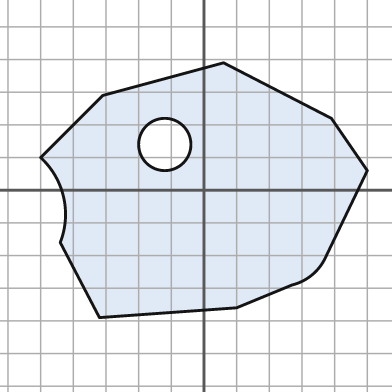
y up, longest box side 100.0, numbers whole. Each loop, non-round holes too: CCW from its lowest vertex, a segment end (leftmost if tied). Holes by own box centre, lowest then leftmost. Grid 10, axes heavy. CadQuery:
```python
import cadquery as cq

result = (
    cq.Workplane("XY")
    .moveTo(-32.0, -39.0)
    .lineTo(10.0, -36.0)
    .lineTo(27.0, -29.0)
    .threePointArc((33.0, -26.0), (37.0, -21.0))
    .lineTo(50.0, 6.0)
    .lineTo(39.0, 22.0)
    .lineTo(6.0, 39.0)
    .lineTo(-31.0, 29.0)
    .lineTo(-50.0, 10.0)
    .threePointArc((-43.0, -2.0), (-44.0, -16.0))
    .close()
    .moveTo(-12.0, 14.0)
    .circle(8.0)
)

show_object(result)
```